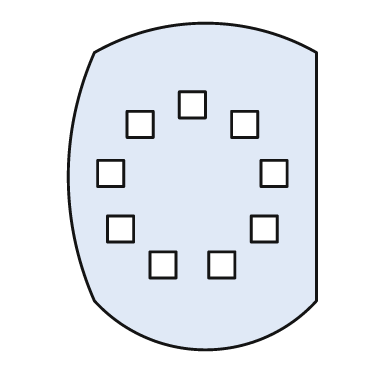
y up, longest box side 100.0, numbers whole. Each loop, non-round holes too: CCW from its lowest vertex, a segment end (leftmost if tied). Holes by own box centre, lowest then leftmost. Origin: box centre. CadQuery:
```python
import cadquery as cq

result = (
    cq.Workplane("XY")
    .moveTo(-30.0, -35.0)
    .threePointArc((4.0, -50.0), (38.0, -35.0))
    .lineTo(38.0, 41.0)
    .threePointArc((4.0, 50.0), (-30.0, 41.0))
    .threePointArc((-38.0, 3.0), (-30.0, -35.0))
    .close()
    .moveTo(-13.0, -28.0)
    .lineTo(-5.0, -28.0)
    .lineTo(-5.0, -20.0)
    .lineTo(-13.0, -20.0)
    .close()
    .moveTo(5.0, -28.0)
    .lineTo(13.0, -28.0)
    .lineTo(13.0, -20.0)
    .lineTo(5.0, -20.0)
    .close()
    .moveTo(-26.0, -17.0)
    .lineTo(-18.0, -17.0)
    .lineTo(-18.0, -9.0)
    .lineTo(-26.0, -9.0)
    .close()
    .moveTo(18.0, -17.0)
    .lineTo(26.0, -17.0)
    .lineTo(26.0, -9.0)
    .lineTo(18.0, -9.0)
    .close()
    .moveTo(-29.0, 0.0)
    .lineTo(-21.0, 0.0)
    .lineTo(-21.0, 8.0)
    .lineTo(-29.0, 8.0)
    .close()
    .moveTo(21.0, 0.0)
    .lineTo(29.0, 0.0)
    .lineTo(29.0, 8.0)
    .lineTo(21.0, 8.0)
    .close()
    .moveTo(-20.0, 15.0)
    .lineTo(-12.0, 15.0)
    .lineTo(-12.0, 23.0)
    .lineTo(-20.0, 23.0)
    .close()
    .moveTo(12.0, 15.0)
    .lineTo(20.0, 15.0)
    .lineTo(20.0, 23.0)
    .lineTo(12.0, 23.0)
    .close()
    .moveTo(-4.0, 21.0)
    .lineTo(4.0, 21.0)
    .lineTo(4.0, 29.0)
    .lineTo(-4.0, 29.0)
    .close()
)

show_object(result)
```